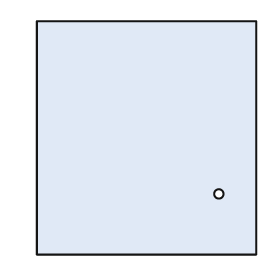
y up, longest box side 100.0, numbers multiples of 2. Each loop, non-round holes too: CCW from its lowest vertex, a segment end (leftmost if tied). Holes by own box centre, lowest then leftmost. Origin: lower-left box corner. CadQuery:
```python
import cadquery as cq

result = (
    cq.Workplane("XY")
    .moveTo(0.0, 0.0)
    .lineTo(94.0, 0.0)
    .lineTo(94.0, 100.0)
    .lineTo(0.0, 100.0)
    .close()
    .moveTo(78.0, 26.0)
    .circle(2.0)
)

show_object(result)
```